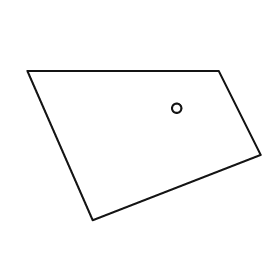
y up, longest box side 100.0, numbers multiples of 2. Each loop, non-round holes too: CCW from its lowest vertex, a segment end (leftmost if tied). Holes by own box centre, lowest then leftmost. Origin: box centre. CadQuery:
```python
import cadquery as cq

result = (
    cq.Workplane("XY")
    .moveTo(-22.0, -32.0)
    .lineTo(50.0, -4.0)
    .lineTo(32.0, 32.0)
    .lineTo(-50.0, 32.0)
    .close()
    .moveTo(14.0, 16.0)
    .circle(2.0)
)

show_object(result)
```